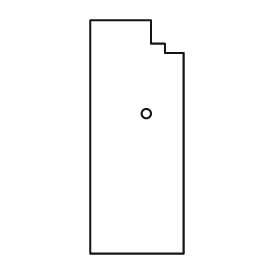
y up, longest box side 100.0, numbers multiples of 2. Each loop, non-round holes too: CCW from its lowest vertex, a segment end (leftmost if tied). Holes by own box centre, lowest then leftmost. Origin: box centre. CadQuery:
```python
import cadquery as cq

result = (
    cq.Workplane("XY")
    .moveTo(-20.0, -50.0)
    .lineTo(20.0, -50.0)
    .lineTo(20.0, 36.0)
    .lineTo(12.0, 36.0)
    .lineTo(12.0, 40.0)
    .lineTo(6.0, 40.0)
    .lineTo(6.0, 50.0)
    .lineTo(-20.0, 50.0)
    .close()
    .moveTo(4.0, 10.0)
    .circle(2.0)
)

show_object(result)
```